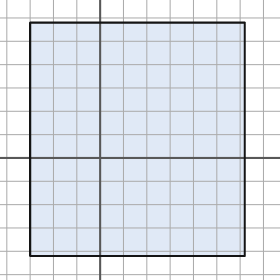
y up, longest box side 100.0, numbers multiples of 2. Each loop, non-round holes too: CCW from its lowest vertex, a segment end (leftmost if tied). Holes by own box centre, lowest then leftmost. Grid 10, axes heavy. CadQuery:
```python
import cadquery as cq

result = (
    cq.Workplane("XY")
    .moveTo(-30.0, -42.0)
    .lineTo(62.0, -42.0)
    .lineTo(62.0, 58.0)
    .lineTo(-30.0, 58.0)
    .close()
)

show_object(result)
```